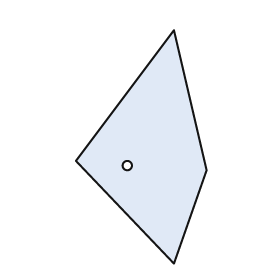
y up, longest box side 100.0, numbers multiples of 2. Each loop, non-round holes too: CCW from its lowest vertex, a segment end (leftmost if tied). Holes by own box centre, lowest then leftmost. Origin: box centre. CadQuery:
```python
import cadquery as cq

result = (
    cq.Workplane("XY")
    .moveTo(14.0, -50.0)
    .lineTo(28.0, -10.0)
    .lineTo(14.0, 50.0)
    .lineTo(-28.0, -6.0)
    .close()
    .moveTo(-6.0, -8.0)
    .circle(2.0)
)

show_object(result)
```